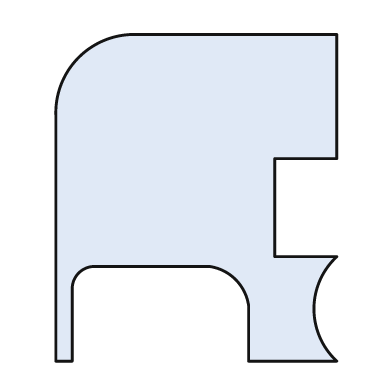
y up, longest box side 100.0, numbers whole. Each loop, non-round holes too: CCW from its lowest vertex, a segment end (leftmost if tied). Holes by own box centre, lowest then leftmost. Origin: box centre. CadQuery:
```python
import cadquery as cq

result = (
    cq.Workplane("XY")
    .moveTo(-43.0, -50.0)
    .lineTo(-38.0, -50.0)
    .lineTo(-38.0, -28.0)
    .threePointArc((-36.0, -23.0), (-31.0, -21.0))
    .lineTo(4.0, -21.0)
    .threePointArc((12.0, -25.0), (16.0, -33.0))
    .lineTo(16.0, -50.0)
    .lineTo(43.0, -50.0)
    .threePointArc((36.0, -34.0), (43.0, -18.0))
    .lineTo(24.0, -18.0)
    .lineTo(24.0, 12.0)
    .lineTo(43.0, 12.0)
    .lineTo(43.0, 50.0)
    .lineTo(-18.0, 50.0)
    .threePointArc((-36.0, 43.0), (-43.0, 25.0))
    .close()
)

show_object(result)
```